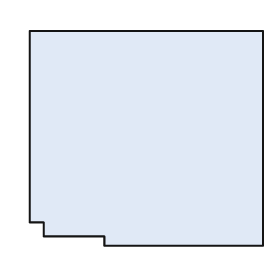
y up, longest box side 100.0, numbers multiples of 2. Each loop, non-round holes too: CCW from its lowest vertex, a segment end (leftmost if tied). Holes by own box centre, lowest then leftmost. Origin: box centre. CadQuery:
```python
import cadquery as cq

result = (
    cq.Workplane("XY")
    .moveTo(-18.0, -46.0)
    .lineTo(50.0, -46.0)
    .lineTo(50.0, 46.0)
    .lineTo(-50.0, 46.0)
    .lineTo(-50.0, -36.0)
    .lineTo(-44.0, -36.0)
    .lineTo(-44.0, -42.0)
    .lineTo(-18.0, -42.0)
    .close()
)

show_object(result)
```